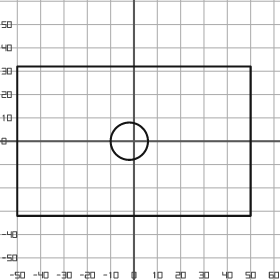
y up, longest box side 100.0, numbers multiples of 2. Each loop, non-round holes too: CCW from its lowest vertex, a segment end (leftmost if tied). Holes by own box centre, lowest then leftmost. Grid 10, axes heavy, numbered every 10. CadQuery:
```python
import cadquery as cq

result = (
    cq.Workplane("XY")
    .moveTo(-50.0, -32.0)
    .lineTo(50.0, -32.0)
    .lineTo(50.0, 32.0)
    .lineTo(-50.0, 32.0)
    .close()
    .moveTo(-2.0, 0.0)
    .circle(8.0)
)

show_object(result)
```